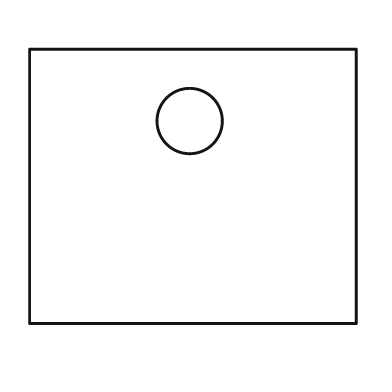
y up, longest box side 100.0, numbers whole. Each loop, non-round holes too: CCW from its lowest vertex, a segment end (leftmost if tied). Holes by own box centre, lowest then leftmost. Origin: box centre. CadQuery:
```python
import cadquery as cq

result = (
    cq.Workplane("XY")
    .moveTo(-50.0, -42.0)
    .lineTo(50.0, -42.0)
    .lineTo(50.0, 42.0)
    .lineTo(-50.0, 42.0)
    .close()
    .moveTo(-1.0, 20.0)
    .circle(10.0)
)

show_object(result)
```